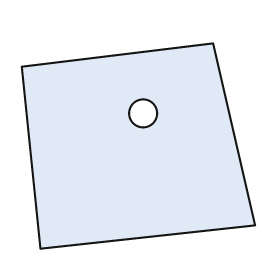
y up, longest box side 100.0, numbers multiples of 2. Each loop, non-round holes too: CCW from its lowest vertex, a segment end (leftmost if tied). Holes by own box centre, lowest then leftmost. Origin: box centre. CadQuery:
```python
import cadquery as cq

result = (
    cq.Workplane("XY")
    .moveTo(-42.0, -44.0)
    .lineTo(50.0, -34.0)
    .lineTo(32.0, 44.0)
    .lineTo(-50.0, 34.0)
    .close()
    .moveTo(2.0, 14.0)
    .circle(6.0)
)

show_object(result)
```